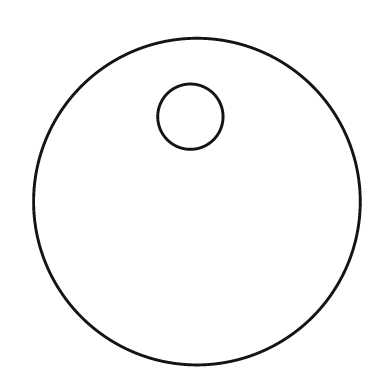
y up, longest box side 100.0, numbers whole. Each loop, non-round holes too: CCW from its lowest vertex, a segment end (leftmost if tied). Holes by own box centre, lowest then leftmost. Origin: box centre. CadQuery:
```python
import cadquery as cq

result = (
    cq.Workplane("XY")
    .moveTo(0.0, 0.0)
    .circle(50.0)
    .moveTo(-2.0, 26.0)
    .circle(10.0)
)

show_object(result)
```